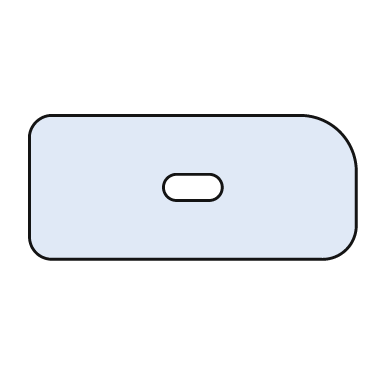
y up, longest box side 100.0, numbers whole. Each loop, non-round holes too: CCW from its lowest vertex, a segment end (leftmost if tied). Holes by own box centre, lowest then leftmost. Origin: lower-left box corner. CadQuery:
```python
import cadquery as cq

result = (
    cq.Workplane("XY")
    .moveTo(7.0, 0.0)
    .lineTo(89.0, 0.0)
    .threePointArc((97.0, 3.0), (100.0, 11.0))
    .lineTo(100.0, 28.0)
    .threePointArc((95.0, 39.0), (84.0, 44.0))
    .lineTo(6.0, 44.0)
    .threePointArc((2.0, 42.0), (0.0, 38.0))
    .lineTo(0.0, 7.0)
    .threePointArc((2.0, 2.0), (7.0, 0.0))
    .close()
    .moveTo(45.0, 18.0)
    .lineTo(55.0, 18.0)
    .threePointArc((59.0, 22.0), (55.0, 26.0))
    .lineTo(45.0, 26.0)
    .threePointArc((41.0, 22.0), (45.0, 18.0))
    .close()
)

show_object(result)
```